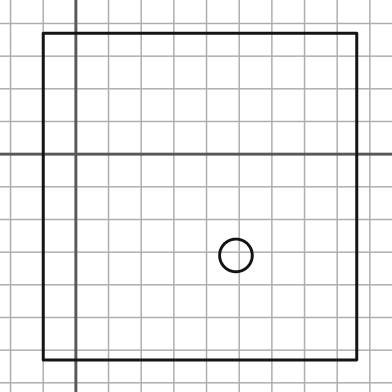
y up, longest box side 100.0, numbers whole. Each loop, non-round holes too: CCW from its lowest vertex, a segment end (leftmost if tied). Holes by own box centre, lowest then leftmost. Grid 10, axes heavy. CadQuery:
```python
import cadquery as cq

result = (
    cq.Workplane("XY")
    .moveTo(-10.0, -63.0)
    .lineTo(86.0, -63.0)
    .lineTo(86.0, 37.0)
    .lineTo(-10.0, 37.0)
    .close()
    .moveTo(49.0, -31.0)
    .circle(5.0)
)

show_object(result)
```